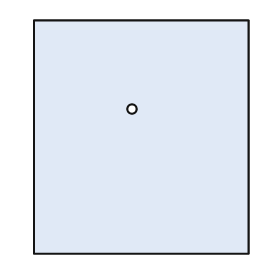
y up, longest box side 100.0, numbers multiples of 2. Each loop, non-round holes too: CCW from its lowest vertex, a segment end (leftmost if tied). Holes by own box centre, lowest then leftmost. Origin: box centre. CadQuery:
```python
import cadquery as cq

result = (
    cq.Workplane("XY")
    .moveTo(-46.0, -50.0)
    .lineTo(46.0, -50.0)
    .lineTo(46.0, 50.0)
    .lineTo(-46.0, 50.0)
    .close()
    .moveTo(-4.0, 12.0)
    .circle(2.0)
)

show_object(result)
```